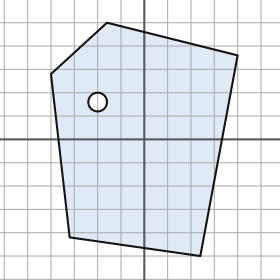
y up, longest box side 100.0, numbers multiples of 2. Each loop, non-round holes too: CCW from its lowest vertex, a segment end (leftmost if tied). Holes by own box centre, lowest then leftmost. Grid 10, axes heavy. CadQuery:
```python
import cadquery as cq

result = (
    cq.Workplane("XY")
    .moveTo(24.0, -50.0)
    .lineTo(40.0, 36.0)
    .lineTo(-16.0, 50.0)
    .lineTo(-40.0, 28.0)
    .lineTo(-32.0, -42.0)
    .close()
    .moveTo(-20.0, 16.0)
    .circle(4.0)
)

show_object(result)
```